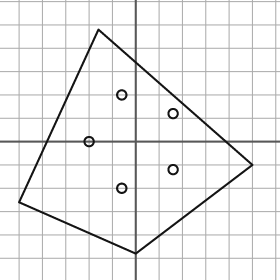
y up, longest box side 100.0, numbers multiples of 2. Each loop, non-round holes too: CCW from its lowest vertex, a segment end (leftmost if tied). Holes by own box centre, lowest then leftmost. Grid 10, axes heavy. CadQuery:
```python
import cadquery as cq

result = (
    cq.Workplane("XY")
    .moveTo(0.0, -48.0)
    .lineTo(50.0, -10.0)
    .lineTo(-16.0, 48.0)
    .lineTo(-50.0, -26.0)
    .close()
    .moveTo(-6.0, -20.0)
    .circle(2.0)
    .moveTo(16.0, -12.0)
    .circle(2.0)
    .moveTo(-20.0, 0.0)
    .circle(2.0)
    .moveTo(16.0, 12.0)
    .circle(2.0)
    .moveTo(-6.0, 20.0)
    .circle(2.0)
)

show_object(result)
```